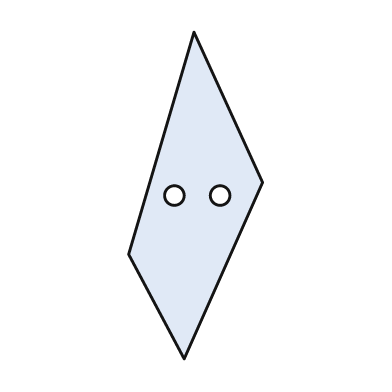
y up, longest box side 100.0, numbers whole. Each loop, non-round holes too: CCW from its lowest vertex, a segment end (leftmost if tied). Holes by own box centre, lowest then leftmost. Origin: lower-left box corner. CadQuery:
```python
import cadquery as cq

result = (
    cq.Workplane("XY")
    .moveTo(17.0, 0.0)
    .lineTo(41.0, 54.0)
    .lineTo(20.0, 100.0)
    .lineTo(0.0, 32.0)
    .close()
    .moveTo(14.0, 50.0)
    .circle(3.0)
    .moveTo(28.0, 50.0)
    .circle(3.0)
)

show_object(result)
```